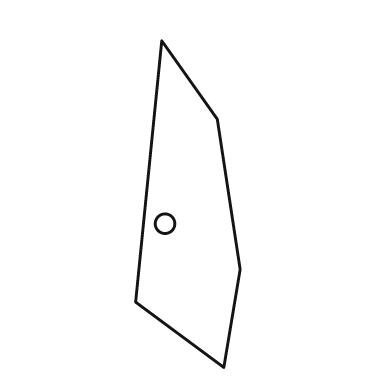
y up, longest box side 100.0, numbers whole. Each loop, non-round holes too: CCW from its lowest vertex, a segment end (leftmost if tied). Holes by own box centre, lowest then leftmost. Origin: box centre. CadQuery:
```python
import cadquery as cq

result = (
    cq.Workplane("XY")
    .moveTo(11.0, -50.0)
    .lineTo(16.0, -20.0)
    .lineTo(9.0, 26.0)
    .lineTo(-8.0, 50.0)
    .lineTo(-16.0, -30.0)
    .close()
    .moveTo(-7.0, -6.0)
    .circle(3.0)
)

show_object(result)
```